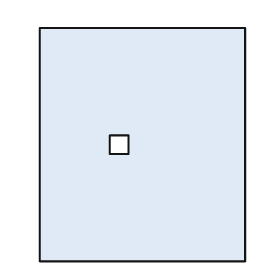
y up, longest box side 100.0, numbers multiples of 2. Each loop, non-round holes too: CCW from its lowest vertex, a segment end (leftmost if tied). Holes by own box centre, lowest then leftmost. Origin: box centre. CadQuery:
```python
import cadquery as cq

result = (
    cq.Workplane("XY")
    .moveTo(-44.0, -50.0)
    .lineTo(44.0, -50.0)
    .lineTo(44.0, 50.0)
    .lineTo(-44.0, 50.0)
    .close()
    .moveTo(-14.0, -4.0)
    .lineTo(-6.0, -4.0)
    .lineTo(-6.0, 4.0)
    .lineTo(-14.0, 4.0)
    .close()
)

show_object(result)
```